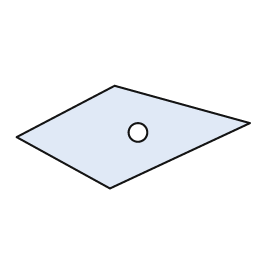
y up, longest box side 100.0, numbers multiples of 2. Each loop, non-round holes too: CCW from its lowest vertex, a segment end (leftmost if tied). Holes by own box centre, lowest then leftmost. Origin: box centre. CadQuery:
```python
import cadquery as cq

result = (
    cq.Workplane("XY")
    .moveTo(-10.0, -22.0)
    .lineTo(50.0, 6.0)
    .lineTo(-8.0, 22.0)
    .lineTo(-50.0, 0.0)
    .close()
    .moveTo(2.0, 2.0)
    .circle(4.0)
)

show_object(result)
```